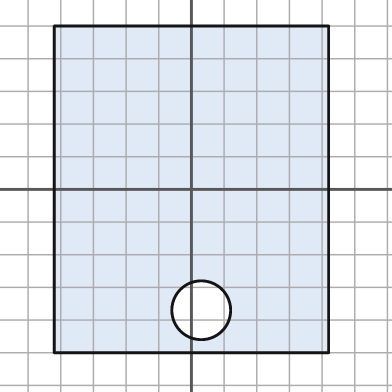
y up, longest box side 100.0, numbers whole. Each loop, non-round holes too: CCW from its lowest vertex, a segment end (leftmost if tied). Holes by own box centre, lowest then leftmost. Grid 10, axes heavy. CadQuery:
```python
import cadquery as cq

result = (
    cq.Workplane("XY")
    .moveTo(-42.0, -50.0)
    .lineTo(42.0, -50.0)
    .lineTo(42.0, 50.0)
    .lineTo(-42.0, 50.0)
    .close()
    .moveTo(3.0, -37.0)
    .circle(9.0)
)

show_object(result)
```